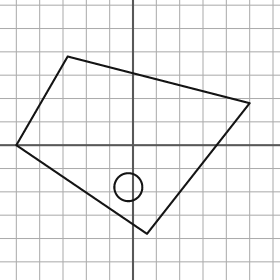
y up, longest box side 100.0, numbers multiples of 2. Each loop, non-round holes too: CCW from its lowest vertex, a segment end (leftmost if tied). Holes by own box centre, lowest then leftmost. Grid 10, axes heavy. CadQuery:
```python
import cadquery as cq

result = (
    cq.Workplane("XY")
    .moveTo(6.0, -38.0)
    .lineTo(50.0, 18.0)
    .lineTo(-28.0, 38.0)
    .lineTo(-50.0, 0.0)
    .close()
    .moveTo(-2.0, -18.0)
    .circle(6.0)
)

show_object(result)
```